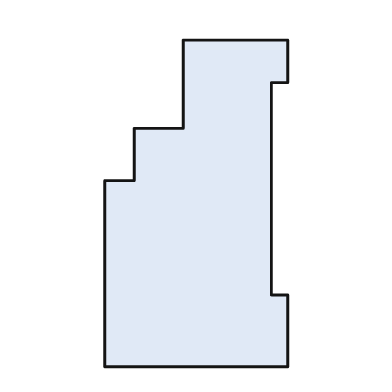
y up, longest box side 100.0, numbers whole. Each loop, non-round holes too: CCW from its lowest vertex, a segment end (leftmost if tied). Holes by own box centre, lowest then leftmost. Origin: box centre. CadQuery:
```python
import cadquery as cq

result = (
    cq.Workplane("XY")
    .moveTo(-28.0, -50.0)
    .lineTo(28.0, -50.0)
    .lineTo(28.0, -28.0)
    .lineTo(23.0, -28.0)
    .lineTo(23.0, 37.0)
    .lineTo(28.0, 37.0)
    .lineTo(28.0, 50.0)
    .lineTo(-4.0, 50.0)
    .lineTo(-4.0, 23.0)
    .lineTo(-19.0, 23.0)
    .lineTo(-19.0, 7.0)
    .lineTo(-28.0, 7.0)
    .close()
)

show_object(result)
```